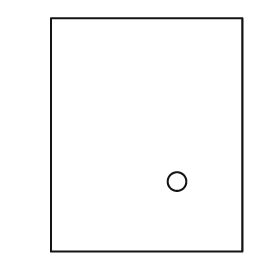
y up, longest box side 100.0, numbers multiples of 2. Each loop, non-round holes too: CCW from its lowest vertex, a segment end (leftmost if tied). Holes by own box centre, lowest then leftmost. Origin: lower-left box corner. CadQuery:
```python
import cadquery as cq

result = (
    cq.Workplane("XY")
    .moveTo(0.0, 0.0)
    .lineTo(82.0, 0.0)
    .lineTo(82.0, 100.0)
    .lineTo(0.0, 100.0)
    .close()
    .moveTo(54.0, 30.0)
    .circle(4.0)
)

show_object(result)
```